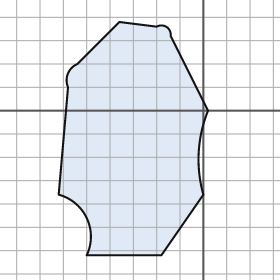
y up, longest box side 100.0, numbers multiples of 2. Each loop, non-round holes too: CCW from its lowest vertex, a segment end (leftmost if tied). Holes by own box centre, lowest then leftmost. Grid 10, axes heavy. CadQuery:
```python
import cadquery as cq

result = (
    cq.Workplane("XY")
    .moveTo(-50.0, -62.0)
    .lineTo(-18.0, -62.0)
    .lineTo(0.0, -36.0)
    .threePointArc((-2.0, -18.0), (2.0, 0.0))
    .lineTo(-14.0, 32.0)
    .threePointArc((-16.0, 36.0), (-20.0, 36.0))
    .lineTo(-36.0, 38.0)
    .lineTo(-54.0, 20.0)
    .threePointArc((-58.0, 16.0), (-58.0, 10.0))
    .lineTo(-62.0, -36.0)
    .threePointArc((-50.0, -46.0), (-50.0, -62.0))
    .close()
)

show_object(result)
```